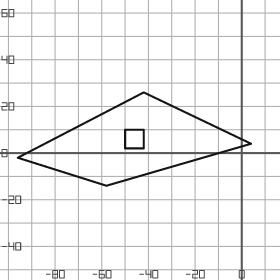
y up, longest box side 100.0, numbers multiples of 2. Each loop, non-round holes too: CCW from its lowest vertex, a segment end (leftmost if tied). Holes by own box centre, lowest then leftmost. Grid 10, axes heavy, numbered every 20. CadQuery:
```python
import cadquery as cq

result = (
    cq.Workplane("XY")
    .moveTo(-58.0, -14.0)
    .lineTo(4.0, 4.0)
    .lineTo(-42.0, 26.0)
    .lineTo(-96.0, -2.0)
    .close()
    .moveTo(-50.0, 2.0)
    .lineTo(-42.0, 2.0)
    .lineTo(-42.0, 10.0)
    .lineTo(-50.0, 10.0)
    .close()
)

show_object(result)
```